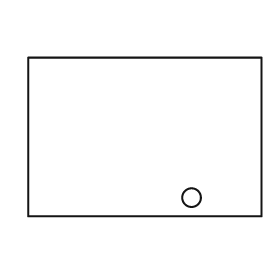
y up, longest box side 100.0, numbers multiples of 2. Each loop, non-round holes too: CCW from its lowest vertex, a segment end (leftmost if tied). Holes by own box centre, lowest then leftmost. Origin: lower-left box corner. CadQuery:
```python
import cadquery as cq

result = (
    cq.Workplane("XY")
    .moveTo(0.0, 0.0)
    .lineTo(100.0, 0.0)
    .lineTo(100.0, 68.0)
    .lineTo(0.0, 68.0)
    .close()
    .moveTo(70.0, 8.0)
    .circle(4.0)
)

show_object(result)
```